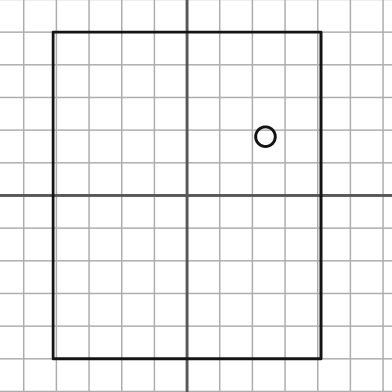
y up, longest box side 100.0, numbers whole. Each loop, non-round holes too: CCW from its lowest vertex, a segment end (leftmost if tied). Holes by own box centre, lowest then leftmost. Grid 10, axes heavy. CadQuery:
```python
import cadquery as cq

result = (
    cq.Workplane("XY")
    .moveTo(-41.0, -50.0)
    .lineTo(41.0, -50.0)
    .lineTo(41.0, 50.0)
    .lineTo(-41.0, 50.0)
    .close()
    .moveTo(24.0, 18.0)
    .circle(3.0)
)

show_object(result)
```